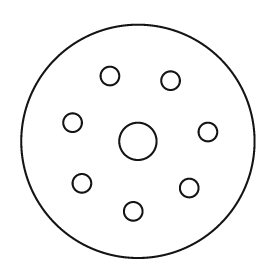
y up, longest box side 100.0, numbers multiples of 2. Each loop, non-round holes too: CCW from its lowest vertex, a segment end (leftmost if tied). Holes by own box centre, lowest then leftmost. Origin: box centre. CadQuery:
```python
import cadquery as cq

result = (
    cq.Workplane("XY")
    .moveTo(0.0, 0.0)
    .circle(50.0)
    .moveTo(-2.0, -30.0)
    .circle(4.0)
    .moveTo(22.0, -20.0)
    .circle(4.0)
    .moveTo(-24.0, -18.0)
    .circle(4.0)
    .moveTo(0.0, 0.0)
    .circle(8.0)
    .moveTo(30.0, 4.0)
    .circle(4.0)
    .moveTo(-28.0, 8.0)
    .circle(4.0)
    .moveTo(14.0, 26.0)
    .circle(4.0)
    .moveTo(-12.0, 28.0)
    .circle(4.0)
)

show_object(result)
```